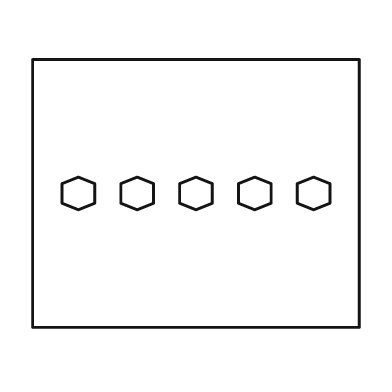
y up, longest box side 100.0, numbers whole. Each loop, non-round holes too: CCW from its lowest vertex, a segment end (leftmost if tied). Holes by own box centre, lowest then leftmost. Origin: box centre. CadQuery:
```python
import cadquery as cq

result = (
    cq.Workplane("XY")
    .moveTo(-50.0, -41.0)
    .lineTo(50.0, -41.0)
    .lineTo(50.0, 41.0)
    .lineTo(-50.0, 41.0)
    .close()
    .moveTo(-36.0, -5.0)
    .lineTo(-31.0, -3.0)
    .lineTo(-31.0, 3.0)
    .lineTo(-36.0, 5.0)
    .lineTo(-41.0, 3.0)
    .lineTo(-41.0, -3.0)
    .close()
    .moveTo(-18.0, -5.0)
    .lineTo(-13.0, -3.0)
    .lineTo(-13.0, 3.0)
    .lineTo(-18.0, 5.0)
    .lineTo(-23.0, 3.0)
    .lineTo(-23.0, -3.0)
    .close()
    .moveTo(0.0, -5.0)
    .lineTo(5.0, -3.0)
    .lineTo(5.0, 3.0)
    .lineTo(0.0, 5.0)
    .lineTo(-5.0, 3.0)
    .lineTo(-5.0, -3.0)
    .close()
    .moveTo(18.0, -5.0)
    .lineTo(23.0, -3.0)
    .lineTo(23.0, 3.0)
    .lineTo(18.0, 5.0)
    .lineTo(13.0, 3.0)
    .lineTo(13.0, -3.0)
    .close()
    .moveTo(36.0, -5.0)
    .lineTo(41.0, -3.0)
    .lineTo(41.0, 3.0)
    .lineTo(36.0, 5.0)
    .lineTo(31.0, 3.0)
    .lineTo(31.0, -3.0)
    .close()
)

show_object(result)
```